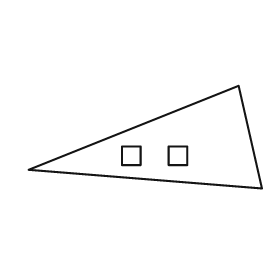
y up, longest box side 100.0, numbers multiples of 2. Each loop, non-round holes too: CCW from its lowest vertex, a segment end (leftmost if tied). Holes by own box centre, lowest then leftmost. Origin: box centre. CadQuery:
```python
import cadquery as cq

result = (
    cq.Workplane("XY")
    .moveTo(50.0, -22.0)
    .lineTo(40.0, 22.0)
    .lineTo(-50.0, -14.0)
    .close()
    .moveTo(-10.0, -12.0)
    .lineTo(-2.0, -12.0)
    .lineTo(-2.0, -4.0)
    .lineTo(-10.0, -4.0)
    .close()
    .moveTo(10.0, -12.0)
    .lineTo(18.0, -12.0)
    .lineTo(18.0, -4.0)
    .lineTo(10.0, -4.0)
    .close()
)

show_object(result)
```